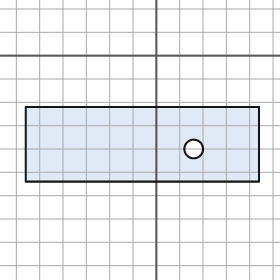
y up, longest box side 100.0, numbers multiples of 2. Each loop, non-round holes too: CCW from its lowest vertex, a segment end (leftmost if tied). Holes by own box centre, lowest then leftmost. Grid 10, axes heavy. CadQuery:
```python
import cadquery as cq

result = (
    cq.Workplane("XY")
    .moveTo(-56.0, -54.0)
    .lineTo(44.0, -54.0)
    .lineTo(44.0, -22.0)
    .lineTo(-56.0, -22.0)
    .close()
    .moveTo(16.0, -40.0)
    .circle(4.0)
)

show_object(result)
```